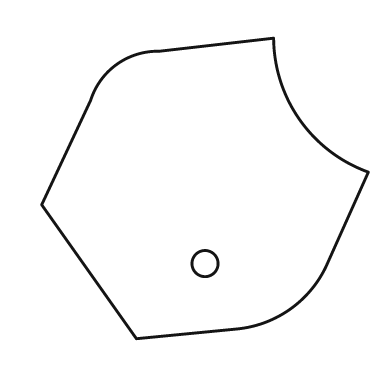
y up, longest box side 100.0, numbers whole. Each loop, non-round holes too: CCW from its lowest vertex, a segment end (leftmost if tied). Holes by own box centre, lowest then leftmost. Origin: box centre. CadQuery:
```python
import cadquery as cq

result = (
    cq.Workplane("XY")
    .moveTo(-21.0, -46.0)
    .lineTo(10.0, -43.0)
    .threePointArc((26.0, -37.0), (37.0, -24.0))
    .lineTo(50.0, 5.0)
    .threePointArc((29.0, 21.0), (21.0, 46.0))
    .lineTo(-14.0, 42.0)
    .threePointArc((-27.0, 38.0), (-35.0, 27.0))
    .lineTo(-50.0, -5.0)
    .close()
    .moveTo(0.0, -23.0)
    .circle(4.0)
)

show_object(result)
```